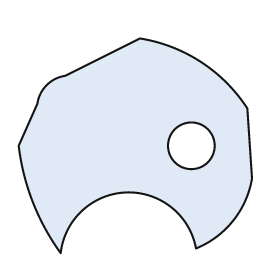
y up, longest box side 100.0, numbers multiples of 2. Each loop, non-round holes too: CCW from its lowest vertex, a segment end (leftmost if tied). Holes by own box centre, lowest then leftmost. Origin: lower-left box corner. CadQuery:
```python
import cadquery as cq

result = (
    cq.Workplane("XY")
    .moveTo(18.0, 0.0)
    .threePointArc((46.0, 26.0), (76.0, 2.0))
    .threePointArc((92.0, 14.0), (100.0, 32.0))
    .lineTo(98.0, 62.0)
    .threePointArc((78.0, 82.0), (52.0, 92.0))
    .lineTo(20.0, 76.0)
    .threePointArc((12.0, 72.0), (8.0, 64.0))
    .lineTo(0.0, 46.0)
    .threePointArc((6.0, 22.0), (18.0, 0.0))
    .close()
    .moveTo(74.0, 46.0)
    .circle(10.0)
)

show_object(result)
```